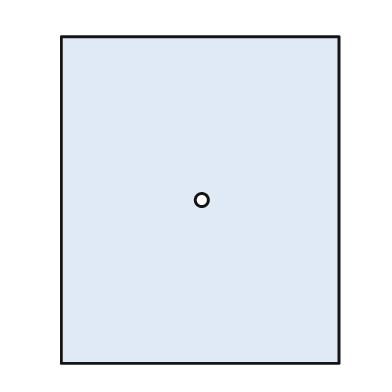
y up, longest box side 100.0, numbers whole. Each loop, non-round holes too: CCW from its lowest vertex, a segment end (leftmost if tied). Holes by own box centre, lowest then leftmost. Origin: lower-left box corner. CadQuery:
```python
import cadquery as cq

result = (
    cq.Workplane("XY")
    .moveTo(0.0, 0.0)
    .lineTo(85.0, 0.0)
    .lineTo(85.0, 100.0)
    .lineTo(0.0, 100.0)
    .close()
    .moveTo(43.0, 50.0)
    .circle(2.0)
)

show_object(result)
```